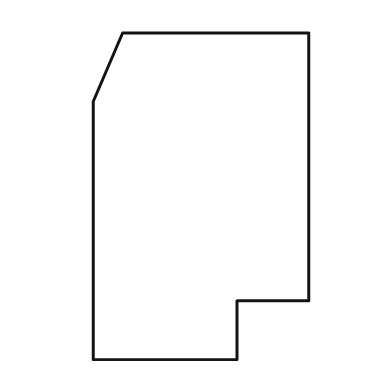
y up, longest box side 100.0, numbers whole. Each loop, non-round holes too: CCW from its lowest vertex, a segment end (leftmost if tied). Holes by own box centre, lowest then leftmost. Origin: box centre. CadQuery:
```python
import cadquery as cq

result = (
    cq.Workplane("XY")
    .moveTo(-33.0, -50.0)
    .lineTo(11.0, -50.0)
    .lineTo(11.0, -32.0)
    .lineTo(33.0, -32.0)
    .lineTo(33.0, 50.0)
    .lineTo(-24.0, 50.0)
    .lineTo(-33.0, 29.0)
    .close()
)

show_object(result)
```